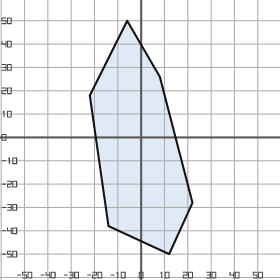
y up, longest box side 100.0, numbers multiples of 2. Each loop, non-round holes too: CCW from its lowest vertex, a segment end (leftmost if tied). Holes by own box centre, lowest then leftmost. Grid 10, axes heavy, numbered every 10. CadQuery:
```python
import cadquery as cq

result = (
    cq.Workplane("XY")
    .moveTo(12.0, -50.0)
    .lineTo(22.0, -28.0)
    .lineTo(8.0, 26.0)
    .lineTo(-6.0, 50.0)
    .lineTo(-22.0, 18.0)
    .lineTo(-14.0, -38.0)
    .close()
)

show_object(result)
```